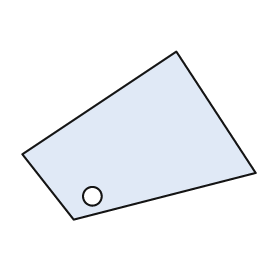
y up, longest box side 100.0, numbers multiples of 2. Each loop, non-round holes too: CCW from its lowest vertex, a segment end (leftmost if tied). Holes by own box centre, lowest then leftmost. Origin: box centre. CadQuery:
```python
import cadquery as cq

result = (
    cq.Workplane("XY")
    .moveTo(-28.0, -36.0)
    .lineTo(50.0, -16.0)
    .lineTo(16.0, 36.0)
    .lineTo(-50.0, -8.0)
    .close()
    .moveTo(-20.0, -26.0)
    .circle(4.0)
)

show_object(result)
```